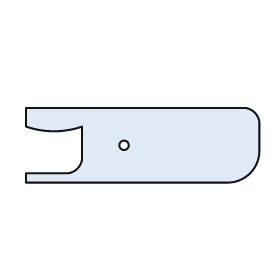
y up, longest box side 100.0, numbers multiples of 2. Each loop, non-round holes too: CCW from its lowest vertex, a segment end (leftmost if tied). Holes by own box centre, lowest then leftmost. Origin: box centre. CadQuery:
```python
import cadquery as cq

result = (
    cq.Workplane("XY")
    .moveTo(-50.0, -16.0)
    .lineTo(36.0, -16.0)
    .threePointArc((46.0, -12.0), (50.0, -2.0))
    .lineTo(50.0, 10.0)
    .threePointArc((48.0, 14.0), (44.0, 16.0))
    .lineTo(-50.0, 16.0)
    .lineTo(-50.0, 8.0)
    .threePointArc((-38.0, 6.0), (-26.0, 8.0))
    .lineTo(-26.0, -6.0)
    .threePointArc((-28.0, -10.0), (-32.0, -12.0))
    .lineTo(-50.0, -12.0)
    .close()
    .moveTo(-8.0, 0.0)
    .circle(2.0)
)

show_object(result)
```